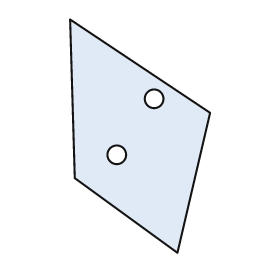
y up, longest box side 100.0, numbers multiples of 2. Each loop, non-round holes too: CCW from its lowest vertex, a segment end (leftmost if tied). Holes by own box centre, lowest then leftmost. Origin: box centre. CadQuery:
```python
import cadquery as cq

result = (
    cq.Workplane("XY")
    .moveTo(16.0, -50.0)
    .lineTo(30.0, 10.0)
    .lineTo(-30.0, 50.0)
    .lineTo(-28.0, -18.0)
    .close()
    .moveTo(-10.0, -8.0)
    .circle(4.0)
    .moveTo(6.0, 16.0)
    .circle(4.0)
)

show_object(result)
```